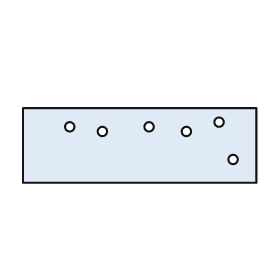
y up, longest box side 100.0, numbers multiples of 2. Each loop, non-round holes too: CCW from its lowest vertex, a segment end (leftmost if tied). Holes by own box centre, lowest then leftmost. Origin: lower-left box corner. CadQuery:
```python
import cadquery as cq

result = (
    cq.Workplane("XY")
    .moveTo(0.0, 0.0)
    .lineTo(100.0, 0.0)
    .lineTo(100.0, 32.0)
    .lineTo(0.0, 32.0)
    .close()
    .moveTo(90.0, 10.0)
    .circle(2.0)
    .moveTo(34.0, 22.0)
    .circle(2.0)
    .moveTo(70.0, 22.0)
    .circle(2.0)
    .moveTo(20.0, 24.0)
    .circle(2.0)
    .moveTo(54.0, 24.0)
    .circle(2.0)
    .moveTo(84.0, 26.0)
    .circle(2.0)
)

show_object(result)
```